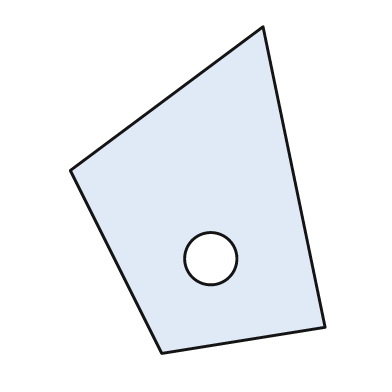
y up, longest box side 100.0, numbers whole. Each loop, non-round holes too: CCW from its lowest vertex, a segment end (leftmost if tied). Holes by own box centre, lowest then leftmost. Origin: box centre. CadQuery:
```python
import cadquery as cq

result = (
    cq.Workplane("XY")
    .moveTo(-11.0, -50.0)
    .lineTo(39.0, -42.0)
    .lineTo(20.0, 50.0)
    .lineTo(-39.0, 6.0)
    .close()
    .moveTo(4.0, -21.0)
    .circle(8.0)
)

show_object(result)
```